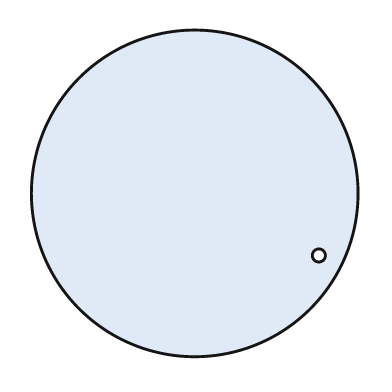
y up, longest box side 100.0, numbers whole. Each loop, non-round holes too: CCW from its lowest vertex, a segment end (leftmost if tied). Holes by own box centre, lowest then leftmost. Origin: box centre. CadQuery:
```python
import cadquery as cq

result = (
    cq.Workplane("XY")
    .moveTo(0.0, 0.0)
    .circle(50.0)
    .moveTo(38.0, -19.0)
    .circle(2.0)
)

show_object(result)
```